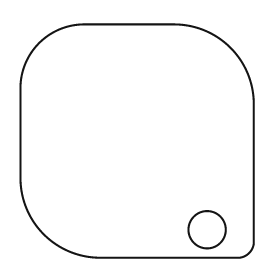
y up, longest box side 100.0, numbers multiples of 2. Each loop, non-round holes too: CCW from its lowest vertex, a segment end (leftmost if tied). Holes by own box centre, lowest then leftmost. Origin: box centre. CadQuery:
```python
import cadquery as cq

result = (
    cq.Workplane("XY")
    .moveTo(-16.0, -50.0)
    .lineTo(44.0, -50.0)
    .threePointArc((48.0, -48.0), (50.0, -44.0))
    .lineTo(50.0, 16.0)
    .threePointArc((40.0, 40.0), (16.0, 50.0))
    .lineTo(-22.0, 50.0)
    .threePointArc((-42.0, 42.0), (-50.0, 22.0))
    .lineTo(-50.0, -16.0)
    .threePointArc((-40.0, -40.0), (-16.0, -50.0))
    .close()
    .moveTo(30.0, -38.0)
    .circle(8.0)
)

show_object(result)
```